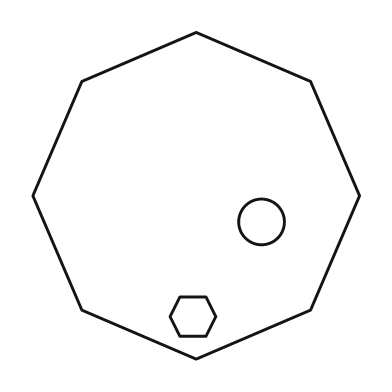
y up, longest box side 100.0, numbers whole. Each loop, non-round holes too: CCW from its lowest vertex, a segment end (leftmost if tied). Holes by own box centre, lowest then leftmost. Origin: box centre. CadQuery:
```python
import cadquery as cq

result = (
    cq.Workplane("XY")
    .moveTo(0.0, -50.0)
    .lineTo(35.0, -35.0)
    .lineTo(50.0, 0.0)
    .lineTo(35.0, 35.0)
    .lineTo(0.0, 50.0)
    .lineTo(-35.0, 35.0)
    .lineTo(-50.0, 0.0)
    .lineTo(-35.0, -35.0)
    .close()
    .moveTo(-5.0, -43.0)
    .lineTo(3.0, -43.0)
    .lineTo(6.0, -37.0)
    .lineTo(3.0, -31.0)
    .lineTo(-5.0, -31.0)
    .lineTo(-8.0, -37.0)
    .close()
    .moveTo(20.0, -8.0)
    .circle(7.0)
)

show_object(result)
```